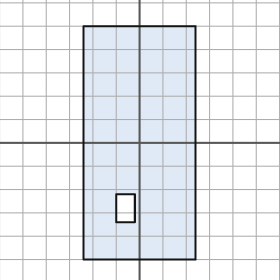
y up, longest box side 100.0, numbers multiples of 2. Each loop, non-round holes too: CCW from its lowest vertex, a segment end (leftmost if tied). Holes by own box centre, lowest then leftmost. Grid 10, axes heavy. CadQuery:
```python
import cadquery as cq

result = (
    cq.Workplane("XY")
    .moveTo(-24.0, -50.0)
    .lineTo(24.0, -50.0)
    .lineTo(24.0, 50.0)
    .lineTo(-24.0, 50.0)
    .close()
    .moveTo(-10.0, -34.0)
    .lineTo(-2.0, -34.0)
    .lineTo(-2.0, -22.0)
    .lineTo(-10.0, -22.0)
    .close()
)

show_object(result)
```